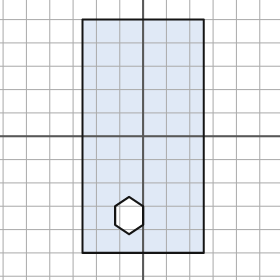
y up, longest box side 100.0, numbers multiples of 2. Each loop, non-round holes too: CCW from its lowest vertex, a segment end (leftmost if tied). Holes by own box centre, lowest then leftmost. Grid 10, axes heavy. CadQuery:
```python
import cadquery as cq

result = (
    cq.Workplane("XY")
    .moveTo(-26.0, -50.0)
    .lineTo(26.0, -50.0)
    .lineTo(26.0, 50.0)
    .lineTo(-26.0, 50.0)
    .close()
    .moveTo(-6.0, -42.0)
    .lineTo(0.0, -38.0)
    .lineTo(0.0, -30.0)
    .lineTo(-6.0, -26.0)
    .lineTo(-12.0, -30.0)
    .lineTo(-12.0, -38.0)
    .close()
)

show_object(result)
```